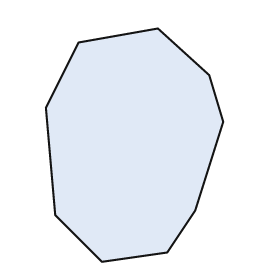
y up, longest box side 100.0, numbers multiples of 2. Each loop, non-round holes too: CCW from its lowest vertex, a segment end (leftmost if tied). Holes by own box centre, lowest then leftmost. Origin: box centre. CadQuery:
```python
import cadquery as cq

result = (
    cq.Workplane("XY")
    .moveTo(-14.0, -50.0)
    .lineTo(14.0, -46.0)
    .lineTo(26.0, -28.0)
    .lineTo(38.0, 10.0)
    .lineTo(32.0, 30.0)
    .lineTo(10.0, 50.0)
    .lineTo(-24.0, 44.0)
    .lineTo(-38.0, 16.0)
    .lineTo(-34.0, -30.0)
    .close()
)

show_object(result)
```